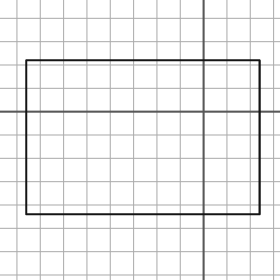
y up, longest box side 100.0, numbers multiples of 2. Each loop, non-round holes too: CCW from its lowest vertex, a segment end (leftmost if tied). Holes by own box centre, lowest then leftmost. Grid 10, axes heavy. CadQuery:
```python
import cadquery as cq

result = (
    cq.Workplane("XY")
    .moveTo(-76.0, -44.0)
    .lineTo(24.0, -44.0)
    .lineTo(24.0, 22.0)
    .lineTo(-76.0, 22.0)
    .close()
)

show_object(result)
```